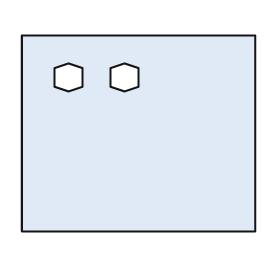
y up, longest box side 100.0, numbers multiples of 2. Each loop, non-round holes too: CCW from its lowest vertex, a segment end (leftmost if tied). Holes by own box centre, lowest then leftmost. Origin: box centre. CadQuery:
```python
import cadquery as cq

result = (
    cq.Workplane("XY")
    .moveTo(-50.0, -42.0)
    .lineTo(50.0, -42.0)
    .lineTo(50.0, 42.0)
    .lineTo(-50.0, 42.0)
    .close()
    .moveTo(-30.0, 18.0)
    .lineTo(-24.0, 20.0)
    .lineTo(-24.0, 28.0)
    .lineTo(-30.0, 30.0)
    .lineTo(-36.0, 28.0)
    .lineTo(-36.0, 20.0)
    .close()
    .moveTo(-6.0, 18.0)
    .lineTo(0.0, 20.0)
    .lineTo(0.0, 28.0)
    .lineTo(-6.0, 30.0)
    .lineTo(-12.0, 28.0)
    .lineTo(-12.0, 20.0)
    .close()
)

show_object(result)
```